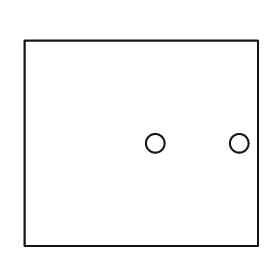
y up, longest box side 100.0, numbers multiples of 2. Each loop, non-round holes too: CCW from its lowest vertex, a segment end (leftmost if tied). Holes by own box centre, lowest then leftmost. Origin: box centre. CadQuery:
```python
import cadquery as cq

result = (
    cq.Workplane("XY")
    .moveTo(-50.0, -44.0)
    .lineTo(50.0, -44.0)
    .lineTo(50.0, 44.0)
    .lineTo(-50.0, 44.0)
    .close()
    .moveTo(6.0, 0.0)
    .circle(4.0)
    .moveTo(42.0, 0.0)
    .circle(4.0)
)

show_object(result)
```